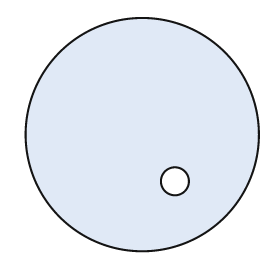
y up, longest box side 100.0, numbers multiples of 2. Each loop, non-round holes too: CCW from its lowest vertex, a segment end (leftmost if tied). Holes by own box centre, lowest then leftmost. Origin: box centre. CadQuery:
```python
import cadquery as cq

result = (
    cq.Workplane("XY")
    .moveTo(0.0, 0.0)
    .circle(50.0)
    .moveTo(14.0, -20.0)
    .circle(6.0)
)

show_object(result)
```